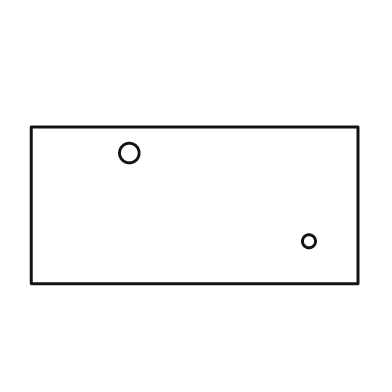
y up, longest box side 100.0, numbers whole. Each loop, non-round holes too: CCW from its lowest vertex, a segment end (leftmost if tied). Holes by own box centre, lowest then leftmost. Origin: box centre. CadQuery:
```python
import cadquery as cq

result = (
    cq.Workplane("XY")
    .moveTo(-50.0, -24.0)
    .lineTo(50.0, -24.0)
    .lineTo(50.0, 24.0)
    .lineTo(-50.0, 24.0)
    .close()
    .moveTo(35.0, -11.0)
    .circle(2.0)
    .moveTo(-20.0, 16.0)
    .circle(3.0)
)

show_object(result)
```